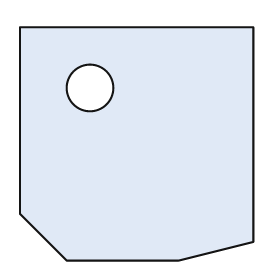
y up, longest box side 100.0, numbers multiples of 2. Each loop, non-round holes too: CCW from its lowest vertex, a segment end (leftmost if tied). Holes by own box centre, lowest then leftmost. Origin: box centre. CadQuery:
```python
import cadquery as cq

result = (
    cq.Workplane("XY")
    .moveTo(-30.0, -50.0)
    .lineTo(18.0, -50.0)
    .lineTo(50.0, -42.0)
    .lineTo(50.0, 50.0)
    .lineTo(-50.0, 50.0)
    .lineTo(-50.0, -30.0)
    .close()
    .moveTo(-20.0, 24.0)
    .circle(10.0)
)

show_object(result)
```